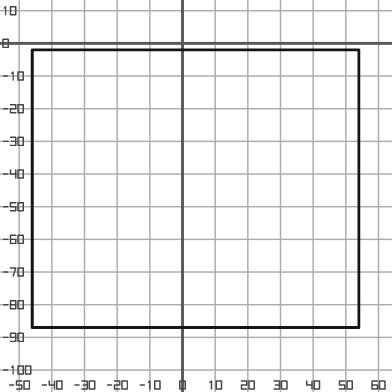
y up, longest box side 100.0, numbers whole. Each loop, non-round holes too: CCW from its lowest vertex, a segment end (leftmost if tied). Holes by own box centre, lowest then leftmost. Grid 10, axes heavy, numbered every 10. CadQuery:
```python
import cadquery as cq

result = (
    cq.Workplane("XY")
    .moveTo(-46.0, -87.0)
    .lineTo(54.0, -87.0)
    .lineTo(54.0, -2.0)
    .lineTo(-46.0, -2.0)
    .close()
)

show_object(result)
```